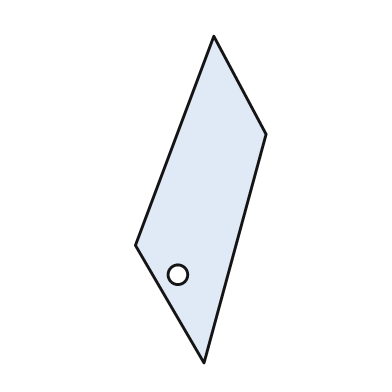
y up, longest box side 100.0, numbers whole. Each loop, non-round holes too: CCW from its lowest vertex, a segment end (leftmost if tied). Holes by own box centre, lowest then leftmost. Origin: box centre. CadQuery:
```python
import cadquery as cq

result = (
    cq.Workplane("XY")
    .moveTo(1.0, -50.0)
    .lineTo(20.0, 20.0)
    .lineTo(4.0, 50.0)
    .lineTo(-20.0, -14.0)
    .close()
    .moveTo(-7.0, -23.0)
    .circle(3.0)
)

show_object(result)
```